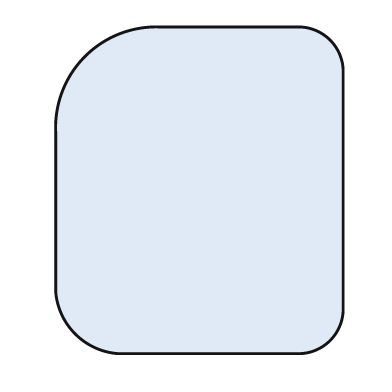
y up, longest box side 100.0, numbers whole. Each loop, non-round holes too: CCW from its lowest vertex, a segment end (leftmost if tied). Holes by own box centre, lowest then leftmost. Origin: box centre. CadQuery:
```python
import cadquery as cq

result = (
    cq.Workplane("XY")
    .moveTo(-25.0, -50.0)
    .lineTo(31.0, -50.0)
    .threePointArc((40.0, -46.0), (44.0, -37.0))
    .lineTo(44.0, 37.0)
    .threePointArc((40.0, 46.0), (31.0, 50.0))
    .lineTo(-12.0, 50.0)
    .threePointArc((-35.0, 41.0), (-44.0, 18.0))
    .lineTo(-44.0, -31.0)
    .threePointArc((-38.0, -44.0), (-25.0, -50.0))
    .close()
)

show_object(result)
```